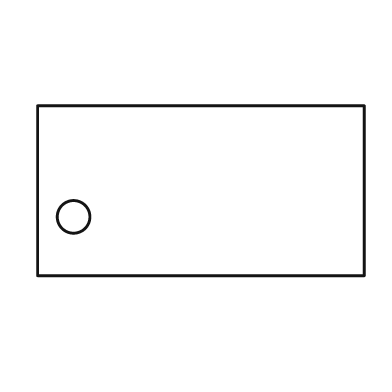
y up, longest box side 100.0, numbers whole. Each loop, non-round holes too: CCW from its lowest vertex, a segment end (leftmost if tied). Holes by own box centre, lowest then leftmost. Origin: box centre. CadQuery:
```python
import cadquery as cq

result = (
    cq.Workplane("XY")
    .moveTo(-50.0, -26.0)
    .lineTo(50.0, -26.0)
    .lineTo(50.0, 26.0)
    .lineTo(-50.0, 26.0)
    .close()
    .moveTo(-39.0, -8.0)
    .circle(5.0)
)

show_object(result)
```